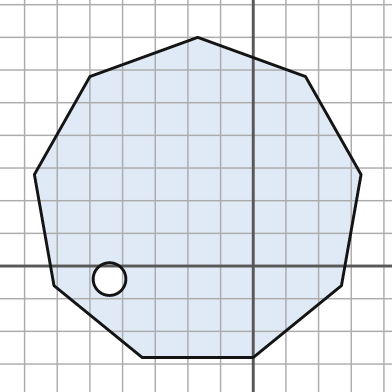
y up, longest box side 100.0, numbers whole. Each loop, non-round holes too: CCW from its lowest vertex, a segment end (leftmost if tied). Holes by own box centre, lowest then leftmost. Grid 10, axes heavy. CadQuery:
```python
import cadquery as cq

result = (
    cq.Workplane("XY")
    .moveTo(-34.0, -28.0)
    .lineTo(0.0, -28.0)
    .lineTo(27.0, -6.0)
    .lineTo(33.0, 28.0)
    .lineTo(16.0, 58.0)
    .lineTo(-17.0, 70.0)
    .lineTo(-50.0, 58.0)
    .lineTo(-67.0, 28.0)
    .lineTo(-61.0, -6.0)
    .close()
    .moveTo(-44.0, -4.0)
    .circle(5.0)
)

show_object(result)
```